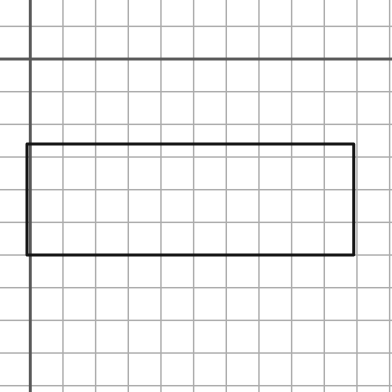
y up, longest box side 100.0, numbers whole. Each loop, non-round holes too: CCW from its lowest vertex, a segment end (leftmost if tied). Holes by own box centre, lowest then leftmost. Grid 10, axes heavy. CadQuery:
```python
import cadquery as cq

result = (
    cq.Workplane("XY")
    .moveTo(-1.0, -60.0)
    .lineTo(99.0, -60.0)
    .lineTo(99.0, -26.0)
    .lineTo(-1.0, -26.0)
    .close()
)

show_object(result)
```